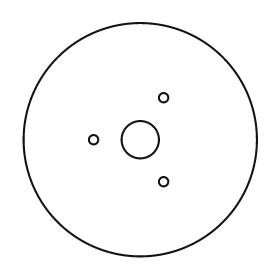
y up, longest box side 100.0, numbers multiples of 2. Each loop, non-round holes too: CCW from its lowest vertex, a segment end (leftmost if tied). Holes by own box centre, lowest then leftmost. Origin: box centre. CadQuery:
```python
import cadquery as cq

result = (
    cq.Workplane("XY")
    .moveTo(0.0, 0.0)
    .circle(50.0)
    .moveTo(10.0, -18.0)
    .circle(2.0)
    .moveTo(-20.0, 0.0)
    .circle(2.0)
    .moveTo(0.0, 0.0)
    .circle(8.0)
    .moveTo(10.0, 18.0)
    .circle(2.0)
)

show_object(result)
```